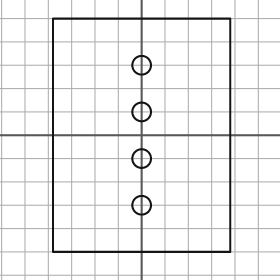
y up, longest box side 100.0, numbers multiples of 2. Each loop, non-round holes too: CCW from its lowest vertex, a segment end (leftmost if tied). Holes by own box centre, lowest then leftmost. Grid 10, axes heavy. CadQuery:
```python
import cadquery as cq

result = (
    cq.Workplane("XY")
    .moveTo(-38.0, -50.0)
    .lineTo(38.0, -50.0)
    .lineTo(38.0, 50.0)
    .lineTo(-38.0, 50.0)
    .close()
    .moveTo(0.0, -30.0)
    .circle(4.0)
    .moveTo(0.0, -10.0)
    .circle(4.0)
    .moveTo(0.0, 10.0)
    .circle(4.0)
    .moveTo(0.0, 30.0)
    .circle(4.0)
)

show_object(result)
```